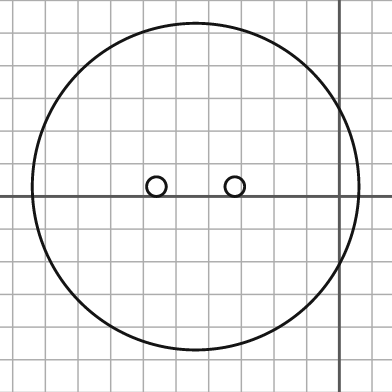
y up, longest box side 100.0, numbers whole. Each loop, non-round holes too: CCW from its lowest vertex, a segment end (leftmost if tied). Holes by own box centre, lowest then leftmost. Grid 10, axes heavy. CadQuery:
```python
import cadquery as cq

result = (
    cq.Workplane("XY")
    .moveTo(-44.0, 3.0)
    .circle(50.0)
    .moveTo(-56.0, 3.0)
    .circle(3.0)
    .moveTo(-32.0, 3.0)
    .circle(3.0)
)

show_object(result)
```